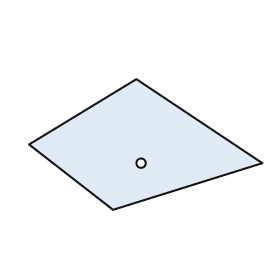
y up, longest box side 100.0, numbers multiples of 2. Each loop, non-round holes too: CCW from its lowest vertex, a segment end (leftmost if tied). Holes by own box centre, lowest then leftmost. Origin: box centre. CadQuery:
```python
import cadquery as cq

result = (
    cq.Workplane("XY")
    .moveTo(-14.0, -28.0)
    .lineTo(50.0, -8.0)
    .lineTo(-4.0, 28.0)
    .lineTo(-50.0, 0.0)
    .close()
    .moveTo(-2.0, -8.0)
    .circle(2.0)
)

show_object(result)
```